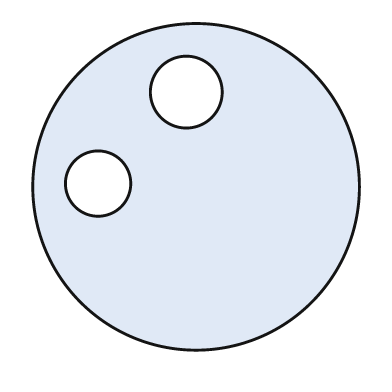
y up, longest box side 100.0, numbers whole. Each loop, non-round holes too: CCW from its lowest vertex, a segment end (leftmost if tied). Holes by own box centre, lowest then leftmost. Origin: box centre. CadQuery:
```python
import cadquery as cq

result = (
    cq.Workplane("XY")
    .moveTo(0.0, 0.0)
    .circle(50.0)
    .moveTo(-30.0, 1.0)
    .circle(10.0)
    .moveTo(-3.0, 29.0)
    .circle(11.0)
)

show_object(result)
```